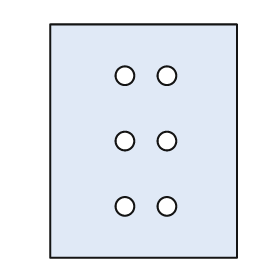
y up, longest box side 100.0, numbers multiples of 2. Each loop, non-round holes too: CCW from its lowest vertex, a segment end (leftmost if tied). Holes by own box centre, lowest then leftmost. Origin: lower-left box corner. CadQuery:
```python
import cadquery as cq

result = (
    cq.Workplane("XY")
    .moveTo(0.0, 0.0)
    .lineTo(80.0, 0.0)
    .lineTo(80.0, 100.0)
    .lineTo(0.0, 100.0)
    .close()
    .moveTo(32.0, 22.0)
    .circle(4.0)
    .moveTo(50.0, 22.0)
    .circle(4.0)
    .moveTo(32.0, 50.0)
    .circle(4.0)
    .moveTo(50.0, 50.0)
    .circle(4.0)
    .moveTo(32.0, 78.0)
    .circle(4.0)
    .moveTo(50.0, 78.0)
    .circle(4.0)
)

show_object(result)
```